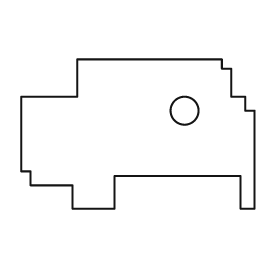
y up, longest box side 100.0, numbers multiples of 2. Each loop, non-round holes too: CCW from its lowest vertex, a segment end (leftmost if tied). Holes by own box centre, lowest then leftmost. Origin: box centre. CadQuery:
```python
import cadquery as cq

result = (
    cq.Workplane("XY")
    .moveTo(-28.0, -32.0)
    .lineTo(-10.0, -32.0)
    .lineTo(-10.0, -18.0)
    .lineTo(44.0, -18.0)
    .lineTo(44.0, -32.0)
    .lineTo(50.0, -32.0)
    .lineTo(50.0, 10.0)
    .lineTo(46.0, 10.0)
    .lineTo(46.0, 16.0)
    .lineTo(40.0, 16.0)
    .lineTo(40.0, 28.0)
    .lineTo(36.0, 28.0)
    .lineTo(36.0, 32.0)
    .lineTo(-26.0, 32.0)
    .lineTo(-26.0, 16.0)
    .lineTo(-50.0, 16.0)
    .lineTo(-50.0, -16.0)
    .lineTo(-46.0, -16.0)
    .lineTo(-46.0, -22.0)
    .lineTo(-28.0, -22.0)
    .close()
    .moveTo(20.0, 10.0)
    .circle(6.0)
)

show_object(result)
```